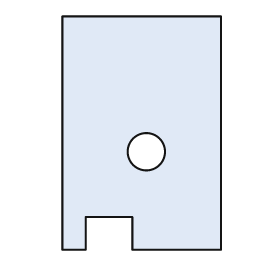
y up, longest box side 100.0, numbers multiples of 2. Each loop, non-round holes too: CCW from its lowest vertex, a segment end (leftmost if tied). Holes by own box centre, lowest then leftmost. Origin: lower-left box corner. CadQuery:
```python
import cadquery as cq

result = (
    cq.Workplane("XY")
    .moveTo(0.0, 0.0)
    .lineTo(10.0, 0.0)
    .lineTo(10.0, 14.0)
    .lineTo(30.0, 14.0)
    .lineTo(30.0, 0.0)
    .lineTo(68.0, 0.0)
    .lineTo(68.0, 100.0)
    .lineTo(0.0, 100.0)
    .close()
    .moveTo(36.0, 42.0)
    .circle(8.0)
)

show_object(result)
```